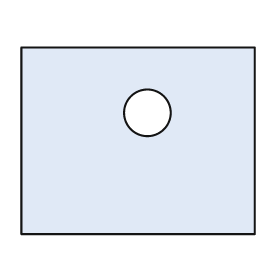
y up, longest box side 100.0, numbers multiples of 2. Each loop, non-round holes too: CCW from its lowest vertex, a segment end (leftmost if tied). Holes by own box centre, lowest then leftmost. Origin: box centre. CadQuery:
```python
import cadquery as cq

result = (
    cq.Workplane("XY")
    .moveTo(-50.0, -40.0)
    .lineTo(50.0, -40.0)
    .lineTo(50.0, 40.0)
    .lineTo(-50.0, 40.0)
    .close()
    .moveTo(4.0, 12.0)
    .circle(10.0)
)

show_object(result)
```